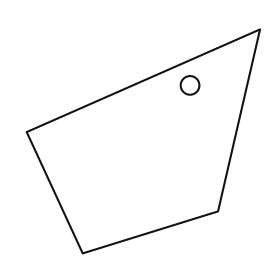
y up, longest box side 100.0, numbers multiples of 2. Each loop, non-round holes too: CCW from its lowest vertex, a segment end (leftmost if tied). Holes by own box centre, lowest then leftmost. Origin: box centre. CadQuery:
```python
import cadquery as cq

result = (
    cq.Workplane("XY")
    .moveTo(-26.0, -48.0)
    .lineTo(32.0, -30.0)
    .lineTo(50.0, 48.0)
    .lineTo(-50.0, 4.0)
    .close()
    .moveTo(20.0, 24.0)
    .circle(4.0)
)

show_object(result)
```